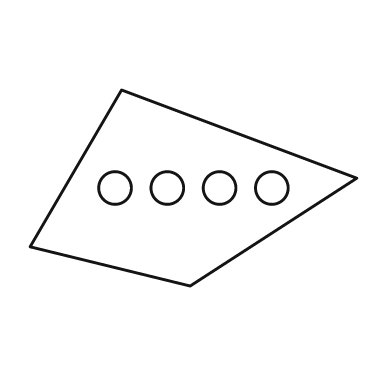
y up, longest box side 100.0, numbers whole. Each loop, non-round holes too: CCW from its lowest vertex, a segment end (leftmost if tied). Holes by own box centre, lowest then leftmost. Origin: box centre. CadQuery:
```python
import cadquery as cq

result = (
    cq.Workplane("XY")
    .moveTo(-1.0, -30.0)
    .lineTo(50.0, 3.0)
    .lineTo(-22.0, 30.0)
    .lineTo(-50.0, -18.0)
    .close()
    .moveTo(-24.0, 0.0)
    .circle(5.0)
    .moveTo(-8.0, 0.0)
    .circle(5.0)
    .moveTo(8.0, 0.0)
    .circle(5.0)
    .moveTo(24.0, 0.0)
    .circle(5.0)
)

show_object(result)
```